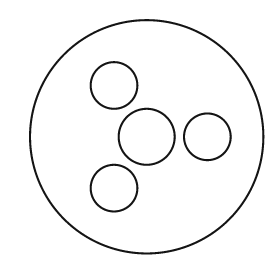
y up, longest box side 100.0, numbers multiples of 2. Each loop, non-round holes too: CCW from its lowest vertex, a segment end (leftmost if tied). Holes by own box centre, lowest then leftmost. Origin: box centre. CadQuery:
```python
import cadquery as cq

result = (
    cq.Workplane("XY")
    .moveTo(0.0, 0.0)
    .circle(50.0)
    .moveTo(-14.0, -22.0)
    .circle(10.0)
    .moveTo(0.0, 0.0)
    .circle(12.0)
    .moveTo(26.0, 0.0)
    .circle(10.0)
    .moveTo(-14.0, 22.0)
    .circle(10.0)
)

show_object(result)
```